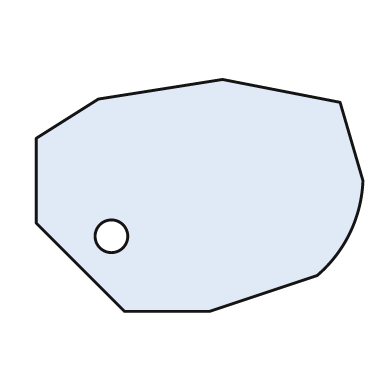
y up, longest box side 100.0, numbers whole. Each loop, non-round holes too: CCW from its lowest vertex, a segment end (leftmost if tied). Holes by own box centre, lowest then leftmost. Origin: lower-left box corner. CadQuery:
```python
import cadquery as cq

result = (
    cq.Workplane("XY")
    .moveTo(27.0, 0.0)
    .lineTo(53.0, 0.0)
    .lineTo(86.0, 11.0)
    .threePointArc((96.0, 24.0), (100.0, 40.0))
    .lineTo(93.0, 64.0)
    .lineTo(57.0, 71.0)
    .lineTo(19.0, 65.0)
    .lineTo(0.0, 53.0)
    .lineTo(0.0, 27.0)
    .close()
    .moveTo(23.0, 23.0)
    .circle(5.0)
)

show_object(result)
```